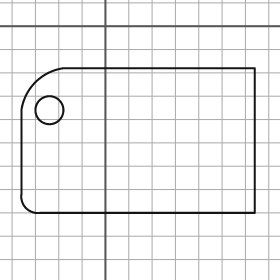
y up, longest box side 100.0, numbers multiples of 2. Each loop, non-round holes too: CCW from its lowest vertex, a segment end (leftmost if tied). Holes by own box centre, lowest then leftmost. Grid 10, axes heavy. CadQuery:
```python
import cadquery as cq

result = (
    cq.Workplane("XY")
    .moveTo(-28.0, -80.0)
    .lineTo(64.0, -80.0)
    .lineTo(64.0, -18.0)
    .lineTo(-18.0, -18.0)
    .threePointArc((-30.0, -24.0), (-36.0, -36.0))
    .lineTo(-36.0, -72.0)
    .threePointArc((-34.0, -78.0), (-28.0, -80.0))
    .close()
    .moveTo(-24.0, -36.0)
    .circle(6.0)
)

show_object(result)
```